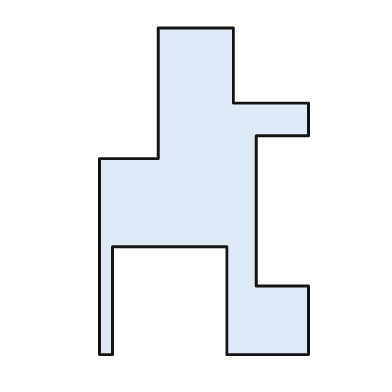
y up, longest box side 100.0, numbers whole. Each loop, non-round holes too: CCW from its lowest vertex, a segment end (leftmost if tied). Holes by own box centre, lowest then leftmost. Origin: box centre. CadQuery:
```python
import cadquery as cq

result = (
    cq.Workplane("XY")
    .moveTo(-32.0, -50.0)
    .lineTo(-28.0, -50.0)
    .lineTo(-28.0, -17.0)
    .lineTo(7.0, -17.0)
    .lineTo(7.0, -50.0)
    .lineTo(32.0, -50.0)
    .lineTo(32.0, -29.0)
    .lineTo(16.0, -29.0)
    .lineTo(16.0, 17.0)
    .lineTo(32.0, 17.0)
    .lineTo(32.0, 27.0)
    .lineTo(9.0, 27.0)
    .lineTo(9.0, 50.0)
    .lineTo(-14.0, 50.0)
    .lineTo(-14.0, 10.0)
    .lineTo(-32.0, 10.0)
    .close()
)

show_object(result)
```